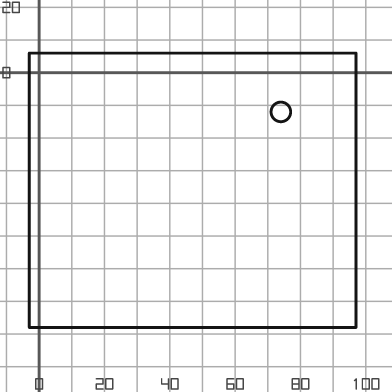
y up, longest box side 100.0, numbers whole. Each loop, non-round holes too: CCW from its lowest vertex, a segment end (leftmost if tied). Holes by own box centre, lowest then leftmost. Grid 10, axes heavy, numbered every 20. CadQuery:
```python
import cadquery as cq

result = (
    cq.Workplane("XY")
    .moveTo(-3.0, -78.0)
    .lineTo(97.0, -78.0)
    .lineTo(97.0, 6.0)
    .lineTo(-3.0, 6.0)
    .close()
    .moveTo(74.0, -12.0)
    .circle(3.0)
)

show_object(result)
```